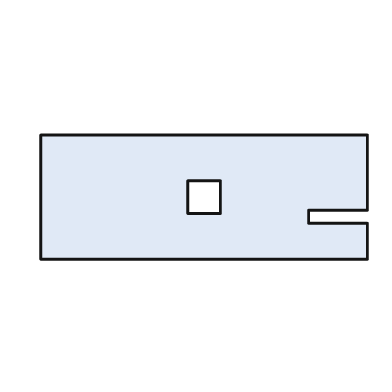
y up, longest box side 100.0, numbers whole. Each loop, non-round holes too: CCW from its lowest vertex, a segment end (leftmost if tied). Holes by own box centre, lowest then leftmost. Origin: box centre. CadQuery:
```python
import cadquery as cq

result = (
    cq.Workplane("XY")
    .moveTo(-50.0, -19.0)
    .lineTo(50.0, -19.0)
    .lineTo(50.0, -8.0)
    .lineTo(32.0, -8.0)
    .lineTo(32.0, -4.0)
    .lineTo(50.0, -4.0)
    .lineTo(50.0, 19.0)
    .lineTo(-50.0, 19.0)
    .close()
    .moveTo(-5.0, -5.0)
    .lineTo(5.0, -5.0)
    .lineTo(5.0, 5.0)
    .lineTo(-5.0, 5.0)
    .close()
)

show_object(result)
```